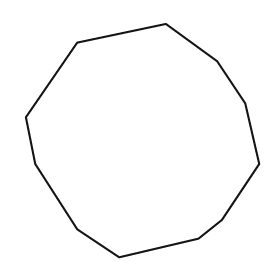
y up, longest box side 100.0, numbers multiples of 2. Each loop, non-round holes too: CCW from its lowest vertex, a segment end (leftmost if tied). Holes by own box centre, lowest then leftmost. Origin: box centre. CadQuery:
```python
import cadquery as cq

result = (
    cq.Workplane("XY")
    .moveTo(-10.0, -50.0)
    .lineTo(24.0, -42.0)
    .lineTo(34.0, -34.0)
    .lineTo(50.0, -10.0)
    .lineTo(44.0, 16.0)
    .lineTo(32.0, 34.0)
    .lineTo(10.0, 50.0)
    .lineTo(-28.0, 42.0)
    .lineTo(-50.0, 10.0)
    .lineTo(-46.0, -10.0)
    .lineTo(-28.0, -38.0)
    .close()
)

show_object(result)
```